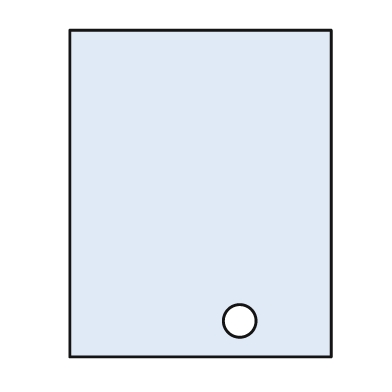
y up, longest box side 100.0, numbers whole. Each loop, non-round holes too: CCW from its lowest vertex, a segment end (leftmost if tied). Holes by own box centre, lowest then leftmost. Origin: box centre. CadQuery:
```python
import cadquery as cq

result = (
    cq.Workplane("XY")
    .moveTo(-40.0, -50.0)
    .lineTo(40.0, -50.0)
    .lineTo(40.0, 50.0)
    .lineTo(-40.0, 50.0)
    .close()
    .moveTo(12.0, -39.0)
    .circle(5.0)
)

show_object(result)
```